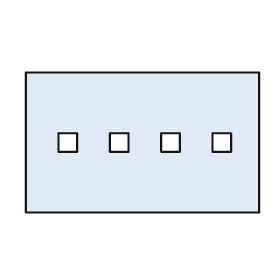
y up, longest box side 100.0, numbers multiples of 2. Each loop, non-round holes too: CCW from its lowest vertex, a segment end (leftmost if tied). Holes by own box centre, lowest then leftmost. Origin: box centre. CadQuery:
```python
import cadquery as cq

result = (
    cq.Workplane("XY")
    .moveTo(-50.0, -30.0)
    .lineTo(50.0, -30.0)
    .lineTo(50.0, 30.0)
    .lineTo(-50.0, 30.0)
    .close()
    .moveTo(-36.0, -4.0)
    .lineTo(-28.0, -4.0)
    .lineTo(-28.0, 4.0)
    .lineTo(-36.0, 4.0)
    .close()
    .moveTo(-14.0, -4.0)
    .lineTo(-6.0, -4.0)
    .lineTo(-6.0, 4.0)
    .lineTo(-14.0, 4.0)
    .close()
    .moveTo(8.0, -4.0)
    .lineTo(16.0, -4.0)
    .lineTo(16.0, 4.0)
    .lineTo(8.0, 4.0)
    .close()
    .moveTo(30.0, -4.0)
    .lineTo(38.0, -4.0)
    .lineTo(38.0, 4.0)
    .lineTo(30.0, 4.0)
    .close()
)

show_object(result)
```